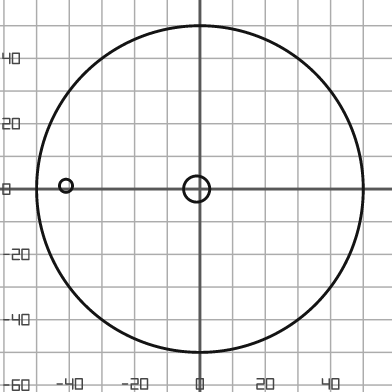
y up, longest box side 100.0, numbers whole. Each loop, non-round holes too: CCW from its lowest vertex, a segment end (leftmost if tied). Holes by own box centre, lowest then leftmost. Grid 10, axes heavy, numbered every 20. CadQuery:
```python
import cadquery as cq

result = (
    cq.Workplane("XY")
    .moveTo(0.0, 0.0)
    .circle(50.0)
    .moveTo(-1.0, 0.0)
    .circle(4.0)
    .moveTo(-41.0, 1.0)
    .circle(2.0)
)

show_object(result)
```